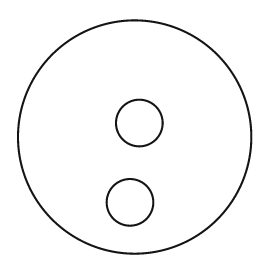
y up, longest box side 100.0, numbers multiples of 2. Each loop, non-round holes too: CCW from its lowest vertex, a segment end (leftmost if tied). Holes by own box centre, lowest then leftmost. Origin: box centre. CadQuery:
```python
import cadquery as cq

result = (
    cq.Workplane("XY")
    .moveTo(0.0, 0.0)
    .circle(50.0)
    .moveTo(-2.0, -28.0)
    .circle(10.0)
    .moveTo(2.0, 6.0)
    .circle(10.0)
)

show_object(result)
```